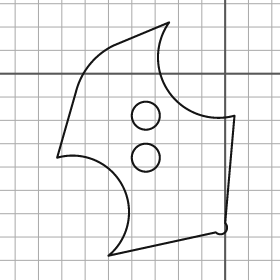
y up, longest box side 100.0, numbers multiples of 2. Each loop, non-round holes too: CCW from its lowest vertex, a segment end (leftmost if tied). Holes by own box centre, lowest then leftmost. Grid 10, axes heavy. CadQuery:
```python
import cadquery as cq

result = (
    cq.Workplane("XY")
    .moveTo(-50.0, -78.0)
    .lineTo(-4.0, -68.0)
    .threePointArc((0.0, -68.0), (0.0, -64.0))
    .lineTo(4.0, -18.0)
    .threePointArc((-24.0, -8.0), (-24.0, 22.0))
    .lineTo(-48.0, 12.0)
    .threePointArc((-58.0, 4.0), (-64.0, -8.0))
    .lineTo(-72.0, -36.0)
    .threePointArc((-44.0, -48.0), (-50.0, -78.0))
    .close()
    .moveTo(-34.0, -36.0)
    .circle(6.0)
    .moveTo(-34.0, -18.0)
    .circle(6.0)
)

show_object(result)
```